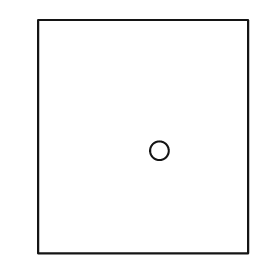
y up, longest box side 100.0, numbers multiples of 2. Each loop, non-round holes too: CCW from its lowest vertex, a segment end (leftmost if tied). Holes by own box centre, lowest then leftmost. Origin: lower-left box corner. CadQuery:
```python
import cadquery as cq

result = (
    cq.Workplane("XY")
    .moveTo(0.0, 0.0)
    .lineTo(90.0, 0.0)
    .lineTo(90.0, 100.0)
    .lineTo(0.0, 100.0)
    .close()
    .moveTo(52.0, 44.0)
    .circle(4.0)
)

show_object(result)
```